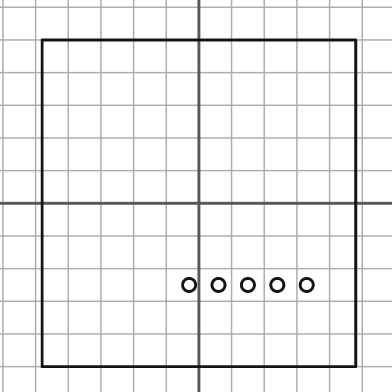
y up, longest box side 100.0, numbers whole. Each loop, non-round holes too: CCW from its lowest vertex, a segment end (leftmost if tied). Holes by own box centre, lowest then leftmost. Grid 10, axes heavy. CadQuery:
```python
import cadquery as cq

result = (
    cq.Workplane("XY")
    .moveTo(-48.0, -50.0)
    .lineTo(48.0, -50.0)
    .lineTo(48.0, 50.0)
    .lineTo(-48.0, 50.0)
    .close()
    .moveTo(-3.0, -25.0)
    .circle(2.0)
    .moveTo(6.0, -25.0)
    .circle(2.0)
    .moveTo(15.0, -25.0)
    .circle(2.0)
    .moveTo(24.0, -25.0)
    .circle(2.0)
    .moveTo(33.0, -25.0)
    .circle(2.0)
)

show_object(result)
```